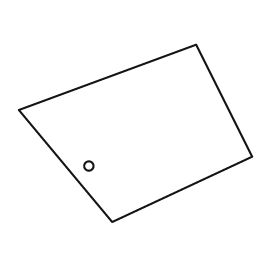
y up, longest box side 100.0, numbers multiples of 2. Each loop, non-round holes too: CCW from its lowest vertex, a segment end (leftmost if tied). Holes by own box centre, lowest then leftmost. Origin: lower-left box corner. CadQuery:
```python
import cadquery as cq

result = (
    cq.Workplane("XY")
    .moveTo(40.0, 0.0)
    .lineTo(100.0, 28.0)
    .lineTo(76.0, 76.0)
    .lineTo(0.0, 48.0)
    .close()
    .moveTo(30.0, 24.0)
    .circle(2.0)
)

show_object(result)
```